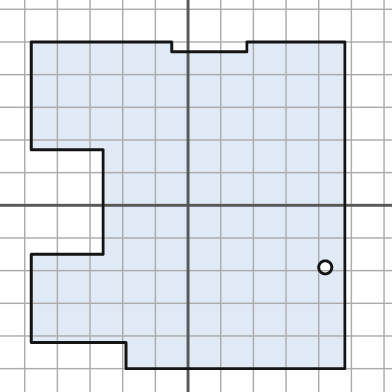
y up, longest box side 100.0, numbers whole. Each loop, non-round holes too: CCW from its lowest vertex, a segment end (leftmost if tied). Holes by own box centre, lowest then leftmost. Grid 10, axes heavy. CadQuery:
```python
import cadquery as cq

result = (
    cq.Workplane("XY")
    .moveTo(-19.0, -50.0)
    .lineTo(48.0, -50.0)
    .lineTo(48.0, 50.0)
    .lineTo(18.0, 50.0)
    .lineTo(18.0, 47.0)
    .lineTo(-5.0, 47.0)
    .lineTo(-5.0, 50.0)
    .lineTo(-48.0, 50.0)
    .lineTo(-48.0, 17.0)
    .lineTo(-26.0, 17.0)
    .lineTo(-26.0, -15.0)
    .lineTo(-48.0, -15.0)
    .lineTo(-48.0, -42.0)
    .lineTo(-19.0, -42.0)
    .close()
    .moveTo(42.0, -19.0)
    .circle(2.0)
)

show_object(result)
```